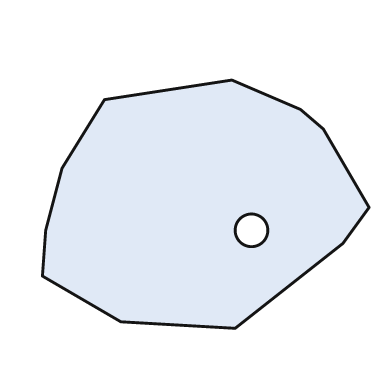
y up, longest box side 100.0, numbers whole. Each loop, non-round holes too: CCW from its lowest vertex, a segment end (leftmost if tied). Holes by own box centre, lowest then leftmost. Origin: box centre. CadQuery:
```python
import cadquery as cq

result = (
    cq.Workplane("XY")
    .moveTo(9.0, -38.0)
    .lineTo(42.0, -12.0)
    .lineTo(50.0, -1.0)
    .lineTo(36.0, 23.0)
    .lineTo(29.0, 29.0)
    .lineTo(8.0, 38.0)
    .lineTo(-31.0, 32.0)
    .lineTo(-44.0, 11.0)
    .lineTo(-49.0, -8.0)
    .lineTo(-50.0, -22.0)
    .lineTo(-26.0, -36.0)
    .close()
    .moveTo(14.0, -8.0)
    .circle(5.0)
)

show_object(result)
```